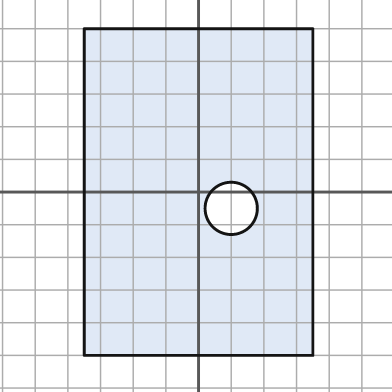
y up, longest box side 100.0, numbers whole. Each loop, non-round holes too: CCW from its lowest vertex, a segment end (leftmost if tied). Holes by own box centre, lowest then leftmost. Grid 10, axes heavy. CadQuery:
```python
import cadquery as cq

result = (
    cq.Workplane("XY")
    .moveTo(-35.0, -50.0)
    .lineTo(35.0, -50.0)
    .lineTo(35.0, 50.0)
    .lineTo(-35.0, 50.0)
    .close()
    .moveTo(10.0, -5.0)
    .circle(8.0)
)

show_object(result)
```